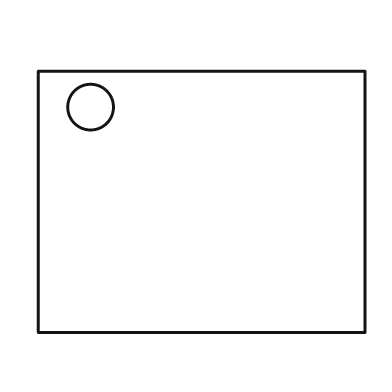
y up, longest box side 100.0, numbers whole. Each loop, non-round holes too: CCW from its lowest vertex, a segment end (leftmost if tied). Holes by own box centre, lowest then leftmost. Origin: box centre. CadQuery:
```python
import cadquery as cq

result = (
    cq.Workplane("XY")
    .moveTo(-50.0, -40.0)
    .lineTo(50.0, -40.0)
    .lineTo(50.0, 40.0)
    .lineTo(-50.0, 40.0)
    .close()
    .moveTo(-34.0, 29.0)
    .circle(7.0)
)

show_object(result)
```